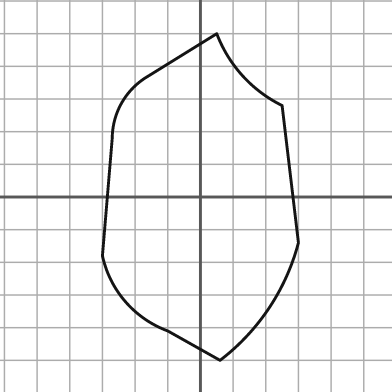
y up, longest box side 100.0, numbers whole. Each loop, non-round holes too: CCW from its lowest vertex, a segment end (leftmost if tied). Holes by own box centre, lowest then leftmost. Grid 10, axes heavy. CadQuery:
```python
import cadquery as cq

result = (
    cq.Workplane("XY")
    .moveTo(6.0, -50.0)
    .threePointArc((21.0, -34.0), (30.0, -14.0))
    .lineTo(25.0, 28.0)
    .threePointArc((13.0, 37.0), (5.0, 50.0))
    .lineTo(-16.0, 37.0)
    .threePointArc((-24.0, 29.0), (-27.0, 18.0))
    .lineTo(-30.0, -18.0)
    .threePointArc((-23.0, -32.0), (-10.0, -41.0))
    .close()
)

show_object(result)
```